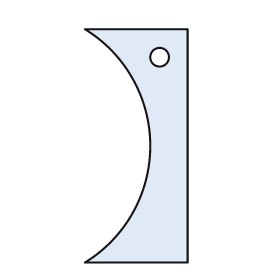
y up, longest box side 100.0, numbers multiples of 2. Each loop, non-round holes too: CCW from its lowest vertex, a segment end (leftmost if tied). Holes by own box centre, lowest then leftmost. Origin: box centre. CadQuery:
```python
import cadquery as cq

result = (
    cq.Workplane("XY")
    .moveTo(-22.0, -50.0)
    .lineTo(22.0, -50.0)
    .lineTo(22.0, 50.0)
    .lineTo(-22.0, 50.0)
    .threePointArc((6.0, 0.0), (-22.0, -50.0))
    .close()
    .moveTo(10.0, 38.0)
    .circle(4.0)
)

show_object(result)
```